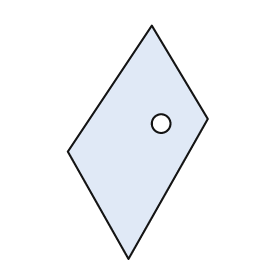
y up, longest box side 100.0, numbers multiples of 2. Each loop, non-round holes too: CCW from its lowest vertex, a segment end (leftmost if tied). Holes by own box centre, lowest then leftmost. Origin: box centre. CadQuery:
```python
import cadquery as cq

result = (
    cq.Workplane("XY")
    .moveTo(-4.0, -50.0)
    .lineTo(30.0, 10.0)
    .lineTo(6.0, 50.0)
    .lineTo(-30.0, -4.0)
    .close()
    .moveTo(10.0, 8.0)
    .circle(4.0)
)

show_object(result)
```